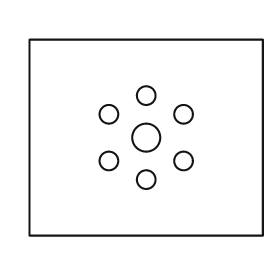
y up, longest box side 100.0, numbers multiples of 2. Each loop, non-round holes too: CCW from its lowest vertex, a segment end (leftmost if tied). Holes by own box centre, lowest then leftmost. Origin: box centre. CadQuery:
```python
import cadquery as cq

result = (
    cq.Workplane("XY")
    .moveTo(-50.0, -42.0)
    .lineTo(50.0, -42.0)
    .lineTo(50.0, 42.0)
    .lineTo(-50.0, 42.0)
    .close()
    .moveTo(0.0, -18.0)
    .circle(4.0)
    .moveTo(-16.0, -10.0)
    .circle(4.0)
    .moveTo(16.0, -10.0)
    .circle(4.0)
    .moveTo(0.0, 0.0)
    .circle(6.0)
    .moveTo(-16.0, 10.0)
    .circle(4.0)
    .moveTo(16.0, 10.0)
    .circle(4.0)
    .moveTo(0.0, 18.0)
    .circle(4.0)
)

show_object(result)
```